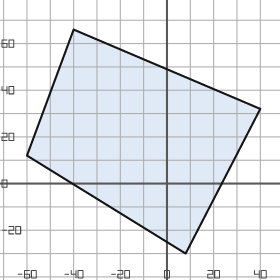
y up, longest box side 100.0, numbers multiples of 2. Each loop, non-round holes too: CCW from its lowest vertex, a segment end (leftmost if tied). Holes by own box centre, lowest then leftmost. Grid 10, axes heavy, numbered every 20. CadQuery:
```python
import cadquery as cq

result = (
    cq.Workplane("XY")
    .moveTo(8.0, -30.0)
    .lineTo(40.0, 32.0)
    .lineTo(-40.0, 66.0)
    .lineTo(-60.0, 12.0)
    .close()
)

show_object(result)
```